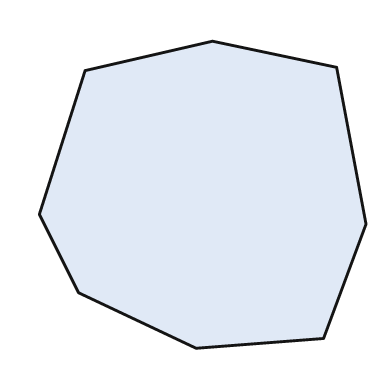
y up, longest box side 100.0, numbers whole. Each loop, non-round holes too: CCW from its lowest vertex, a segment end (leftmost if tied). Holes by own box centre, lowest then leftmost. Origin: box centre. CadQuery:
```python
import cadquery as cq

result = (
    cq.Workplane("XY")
    .moveTo(-2.0, -47.0)
    .lineTo(37.0, -44.0)
    .lineTo(50.0, -9.0)
    .lineTo(41.0, 39.0)
    .lineTo(3.0, 47.0)
    .lineTo(-36.0, 38.0)
    .lineTo(-50.0, -6.0)
    .lineTo(-38.0, -30.0)
    .close()
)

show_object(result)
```